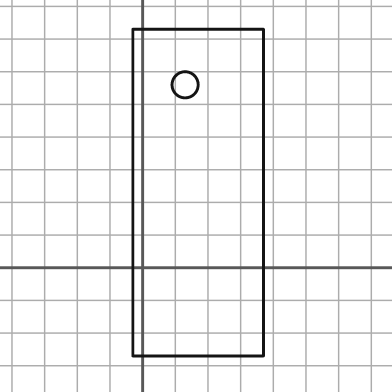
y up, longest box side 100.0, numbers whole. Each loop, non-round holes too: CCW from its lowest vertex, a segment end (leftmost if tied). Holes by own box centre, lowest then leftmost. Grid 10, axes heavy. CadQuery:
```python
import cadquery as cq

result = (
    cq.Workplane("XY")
    .moveTo(-3.0, -27.0)
    .lineTo(37.0, -27.0)
    .lineTo(37.0, 73.0)
    .lineTo(-3.0, 73.0)
    .close()
    .moveTo(13.0, 56.0)
    .circle(4.0)
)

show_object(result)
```